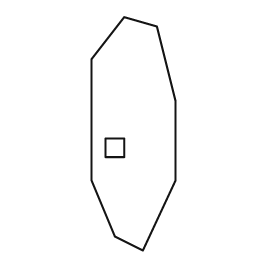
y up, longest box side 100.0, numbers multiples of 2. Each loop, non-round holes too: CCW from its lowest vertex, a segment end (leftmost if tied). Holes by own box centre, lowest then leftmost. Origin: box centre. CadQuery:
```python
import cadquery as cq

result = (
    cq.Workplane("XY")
    .moveTo(4.0, -50.0)
    .lineTo(18.0, -20.0)
    .lineTo(18.0, 14.0)
    .lineTo(10.0, 46.0)
    .lineTo(-4.0, 50.0)
    .lineTo(-18.0, 32.0)
    .lineTo(-18.0, -20.0)
    .lineTo(-8.0, -44.0)
    .close()
    .moveTo(-12.0, -10.0)
    .lineTo(-4.0, -10.0)
    .lineTo(-4.0, -2.0)
    .lineTo(-12.0, -2.0)
    .close()
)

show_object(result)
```